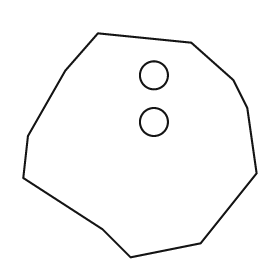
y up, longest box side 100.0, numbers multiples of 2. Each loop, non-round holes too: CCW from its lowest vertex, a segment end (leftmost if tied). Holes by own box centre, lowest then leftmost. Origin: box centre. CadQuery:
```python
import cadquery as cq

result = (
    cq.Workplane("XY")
    .moveTo(-4.0, -48.0)
    .lineTo(26.0, -42.0)
    .lineTo(50.0, -12.0)
    .lineTo(46.0, 16.0)
    .lineTo(40.0, 28.0)
    .lineTo(22.0, 44.0)
    .lineTo(-18.0, 48.0)
    .lineTo(-32.0, 32.0)
    .lineTo(-48.0, 4.0)
    .lineTo(-50.0, -14.0)
    .lineTo(-16.0, -36.0)
    .close()
    .moveTo(6.0, 10.0)
    .circle(6.0)
    .moveTo(6.0, 30.0)
    .circle(6.0)
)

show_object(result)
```